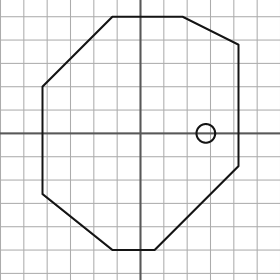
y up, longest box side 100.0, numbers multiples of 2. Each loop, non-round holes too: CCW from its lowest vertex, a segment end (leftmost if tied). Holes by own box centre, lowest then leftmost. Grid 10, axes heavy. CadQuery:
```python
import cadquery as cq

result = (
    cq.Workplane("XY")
    .moveTo(-12.0, -50.0)
    .lineTo(6.0, -50.0)
    .lineTo(42.0, -14.0)
    .lineTo(42.0, 38.0)
    .lineTo(18.0, 50.0)
    .lineTo(-12.0, 50.0)
    .lineTo(-42.0, 20.0)
    .lineTo(-42.0, -26.0)
    .close()
    .moveTo(28.0, 0.0)
    .circle(4.0)
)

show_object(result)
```